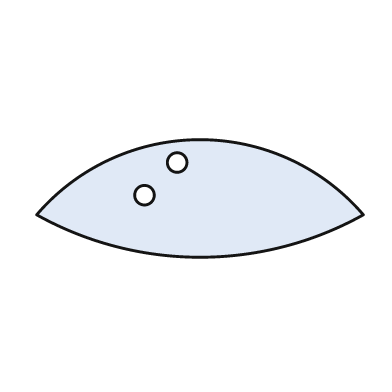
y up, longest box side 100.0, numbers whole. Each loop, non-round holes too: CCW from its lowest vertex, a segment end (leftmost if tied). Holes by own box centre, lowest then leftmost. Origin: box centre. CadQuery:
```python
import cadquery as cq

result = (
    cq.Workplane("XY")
    .moveTo(-50.0, -5.0)
    .threePointArc((0.0, -18.0), (50.0, -5.0))
    .threePointArc((0.0, 18.0), (-50.0, -5.0))
    .close()
    .moveTo(-17.0, 1.0)
    .circle(3.0)
    .moveTo(-7.0, 11.0)
    .circle(3.0)
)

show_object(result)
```